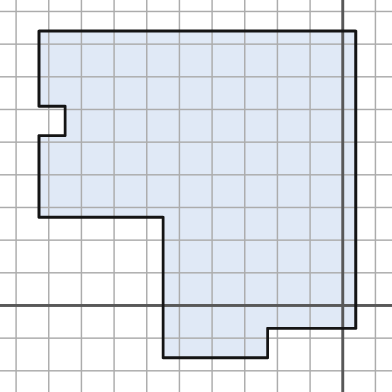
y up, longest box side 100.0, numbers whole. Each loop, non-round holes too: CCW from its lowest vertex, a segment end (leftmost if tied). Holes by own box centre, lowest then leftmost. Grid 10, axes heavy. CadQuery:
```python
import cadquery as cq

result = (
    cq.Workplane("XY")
    .moveTo(-55.0, -16.0)
    .lineTo(-23.0, -16.0)
    .lineTo(-23.0, -7.0)
    .lineTo(4.0, -7.0)
    .lineTo(4.0, 84.0)
    .lineTo(-93.0, 84.0)
    .lineTo(-93.0, 61.0)
    .lineTo(-85.0, 61.0)
    .lineTo(-85.0, 52.0)
    .lineTo(-93.0, 52.0)
    .lineTo(-93.0, 27.0)
    .lineTo(-55.0, 27.0)
    .close()
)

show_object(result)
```